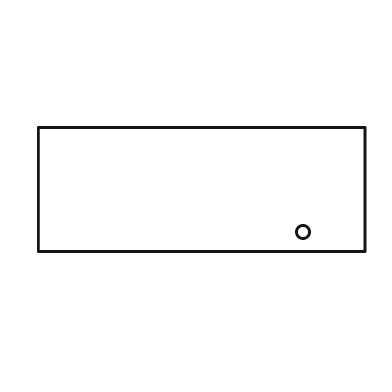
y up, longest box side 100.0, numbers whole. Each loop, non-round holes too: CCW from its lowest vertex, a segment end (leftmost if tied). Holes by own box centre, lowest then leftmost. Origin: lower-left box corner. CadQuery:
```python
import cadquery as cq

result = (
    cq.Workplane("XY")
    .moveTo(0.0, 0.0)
    .lineTo(100.0, 0.0)
    .lineTo(100.0, 38.0)
    .lineTo(0.0, 38.0)
    .close()
    .moveTo(81.0, 6.0)
    .circle(2.0)
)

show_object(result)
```